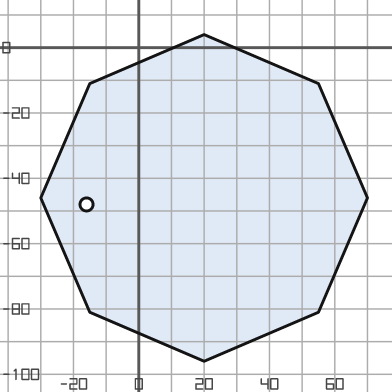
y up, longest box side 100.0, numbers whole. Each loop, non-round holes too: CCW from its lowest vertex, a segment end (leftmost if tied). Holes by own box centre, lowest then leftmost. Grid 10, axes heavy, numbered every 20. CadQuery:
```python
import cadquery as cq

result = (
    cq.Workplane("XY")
    .moveTo(20.0, -96.0)
    .lineTo(55.0, -81.0)
    .lineTo(70.0, -46.0)
    .lineTo(55.0, -11.0)
    .lineTo(20.0, 4.0)
    .lineTo(-15.0, -11.0)
    .lineTo(-30.0, -46.0)
    .lineTo(-15.0, -81.0)
    .close()
    .moveTo(-16.0, -48.0)
    .circle(2.0)
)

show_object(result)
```